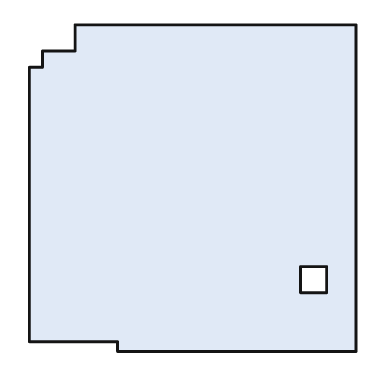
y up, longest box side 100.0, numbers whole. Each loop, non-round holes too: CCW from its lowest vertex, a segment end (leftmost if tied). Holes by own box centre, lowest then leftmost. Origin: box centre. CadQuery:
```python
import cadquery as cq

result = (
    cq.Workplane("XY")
    .moveTo(-23.0, -50.0)
    .lineTo(50.0, -50.0)
    .lineTo(50.0, 50.0)
    .lineTo(-36.0, 50.0)
    .lineTo(-36.0, 42.0)
    .lineTo(-46.0, 42.0)
    .lineTo(-46.0, 37.0)
    .lineTo(-50.0, 37.0)
    .lineTo(-50.0, -47.0)
    .lineTo(-23.0, -47.0)
    .close()
    .moveTo(33.0, -32.0)
    .lineTo(41.0, -32.0)
    .lineTo(41.0, -24.0)
    .lineTo(33.0, -24.0)
    .close()
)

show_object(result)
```